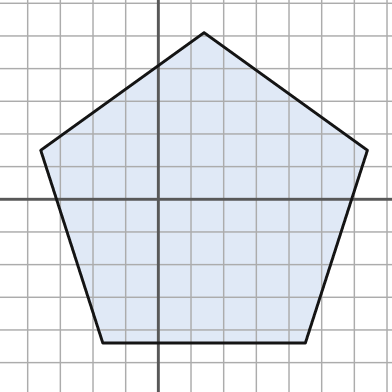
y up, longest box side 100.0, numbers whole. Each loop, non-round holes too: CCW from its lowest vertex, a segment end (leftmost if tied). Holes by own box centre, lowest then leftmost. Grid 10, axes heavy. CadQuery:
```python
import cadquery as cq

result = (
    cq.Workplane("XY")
    .moveTo(-17.0, -44.0)
    .lineTo(45.0, -44.0)
    .lineTo(64.0, 15.0)
    .lineTo(14.0, 51.0)
    .lineTo(-36.0, 15.0)
    .close()
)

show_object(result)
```